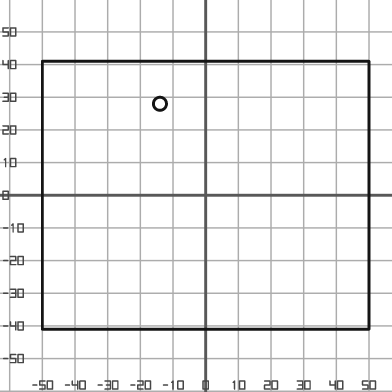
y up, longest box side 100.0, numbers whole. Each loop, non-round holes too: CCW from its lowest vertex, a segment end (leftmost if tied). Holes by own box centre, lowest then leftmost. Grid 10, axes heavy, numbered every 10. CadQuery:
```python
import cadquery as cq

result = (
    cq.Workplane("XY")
    .moveTo(-50.0, -41.0)
    .lineTo(50.0, -41.0)
    .lineTo(50.0, 41.0)
    .lineTo(-50.0, 41.0)
    .close()
    .moveTo(-14.0, 28.0)
    .circle(2.0)
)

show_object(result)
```